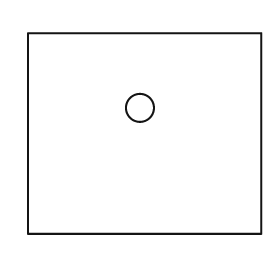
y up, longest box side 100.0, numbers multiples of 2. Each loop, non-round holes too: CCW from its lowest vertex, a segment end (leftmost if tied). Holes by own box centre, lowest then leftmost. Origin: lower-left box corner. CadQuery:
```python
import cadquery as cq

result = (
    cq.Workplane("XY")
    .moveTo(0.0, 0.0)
    .lineTo(100.0, 0.0)
    .lineTo(100.0, 86.0)
    .lineTo(0.0, 86.0)
    .close()
    .moveTo(48.0, 54.0)
    .circle(6.0)
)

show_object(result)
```